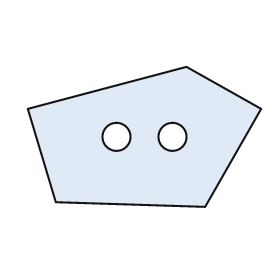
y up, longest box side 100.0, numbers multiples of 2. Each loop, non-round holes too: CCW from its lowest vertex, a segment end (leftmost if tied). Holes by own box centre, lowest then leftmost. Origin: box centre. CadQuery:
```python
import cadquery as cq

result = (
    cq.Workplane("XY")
    .moveTo(26.0, -30.0)
    .lineTo(50.0, 12.0)
    .lineTo(18.0, 30.0)
    .lineTo(-50.0, 12.0)
    .lineTo(-38.0, -28.0)
    .close()
    .moveTo(-12.0, 0.0)
    .circle(6.0)
    .moveTo(12.0, 0.0)
    .circle(6.0)
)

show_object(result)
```